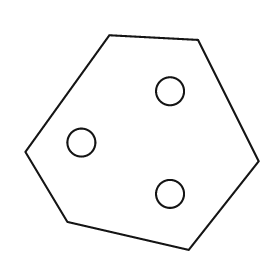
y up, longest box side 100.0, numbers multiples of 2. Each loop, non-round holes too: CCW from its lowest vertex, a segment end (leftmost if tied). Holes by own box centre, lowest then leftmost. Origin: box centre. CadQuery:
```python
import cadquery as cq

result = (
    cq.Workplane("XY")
    .moveTo(20.0, -46.0)
    .lineTo(50.0, -8.0)
    .lineTo(24.0, 44.0)
    .lineTo(-14.0, 46.0)
    .lineTo(-50.0, -4.0)
    .lineTo(-32.0, -34.0)
    .close()
    .moveTo(12.0, -22.0)
    .circle(6.0)
    .moveTo(-26.0, 0.0)
    .circle(6.0)
    .moveTo(12.0, 22.0)
    .circle(6.0)
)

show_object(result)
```